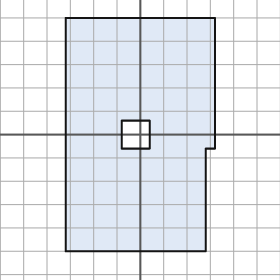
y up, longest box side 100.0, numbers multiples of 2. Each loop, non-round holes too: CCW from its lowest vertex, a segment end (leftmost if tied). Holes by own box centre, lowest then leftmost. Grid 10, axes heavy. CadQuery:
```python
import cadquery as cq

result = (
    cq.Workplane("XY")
    .moveTo(-32.0, -50.0)
    .lineTo(28.0, -50.0)
    .lineTo(28.0, -6.0)
    .lineTo(32.0, -6.0)
    .lineTo(32.0, 50.0)
    .lineTo(-32.0, 50.0)
    .close()
    .moveTo(-8.0, -6.0)
    .lineTo(4.0, -6.0)
    .lineTo(4.0, 6.0)
    .lineTo(-8.0, 6.0)
    .close()
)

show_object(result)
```